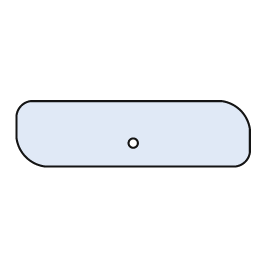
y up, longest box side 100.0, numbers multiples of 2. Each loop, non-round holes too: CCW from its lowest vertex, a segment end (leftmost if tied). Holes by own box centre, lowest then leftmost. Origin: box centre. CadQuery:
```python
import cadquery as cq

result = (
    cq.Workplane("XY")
    .moveTo(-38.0, -14.0)
    .lineTo(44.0, -14.0)
    .threePointArc((48.0, -12.0), (50.0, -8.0))
    .lineTo(50.0, 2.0)
    .threePointArc((46.0, 10.0), (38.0, 14.0))
    .lineTo(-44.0, 14.0)
    .threePointArc((-48.0, 12.0), (-50.0, 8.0))
    .lineTo(-50.0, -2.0)
    .threePointArc((-46.0, -10.0), (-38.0, -14.0))
    .close()
    .moveTo(0.0, -4.0)
    .circle(2.0)
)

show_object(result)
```